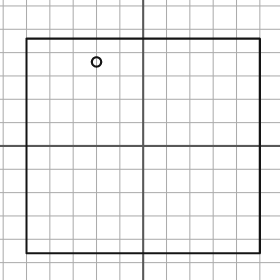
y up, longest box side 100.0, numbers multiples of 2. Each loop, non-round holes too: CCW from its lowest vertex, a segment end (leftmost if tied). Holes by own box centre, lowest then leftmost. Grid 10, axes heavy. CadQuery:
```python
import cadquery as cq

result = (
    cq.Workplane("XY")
    .moveTo(-50.0, -46.0)
    .lineTo(50.0, -46.0)
    .lineTo(50.0, 46.0)
    .lineTo(-50.0, 46.0)
    .close()
    .moveTo(-20.0, 36.0)
    .circle(2.0)
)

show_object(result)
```